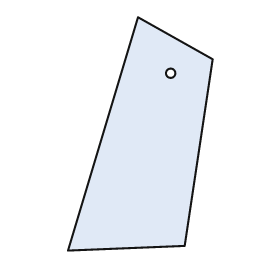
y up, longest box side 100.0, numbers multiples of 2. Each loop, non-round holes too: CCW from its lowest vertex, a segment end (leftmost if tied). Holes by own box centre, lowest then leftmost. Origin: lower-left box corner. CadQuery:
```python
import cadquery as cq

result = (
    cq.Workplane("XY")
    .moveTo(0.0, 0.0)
    .lineTo(50.0, 2.0)
    .lineTo(62.0, 82.0)
    .lineTo(30.0, 100.0)
    .close()
    .moveTo(44.0, 76.0)
    .circle(2.0)
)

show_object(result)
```